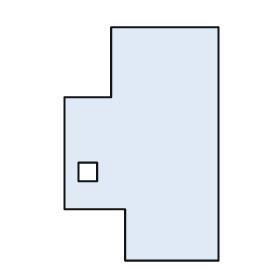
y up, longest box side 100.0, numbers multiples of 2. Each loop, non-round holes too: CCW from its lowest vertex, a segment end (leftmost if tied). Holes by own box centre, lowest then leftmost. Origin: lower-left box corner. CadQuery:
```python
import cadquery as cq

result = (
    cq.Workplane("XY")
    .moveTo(26.0, 0.0)
    .lineTo(66.0, 0.0)
    .lineTo(66.0, 100.0)
    .lineTo(20.0, 100.0)
    .lineTo(20.0, 70.0)
    .lineTo(0.0, 70.0)
    .lineTo(0.0, 22.0)
    .lineTo(26.0, 22.0)
    .close()
    .moveTo(6.0, 34.0)
    .lineTo(14.0, 34.0)
    .lineTo(14.0, 42.0)
    .lineTo(6.0, 42.0)
    .close()
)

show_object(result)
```